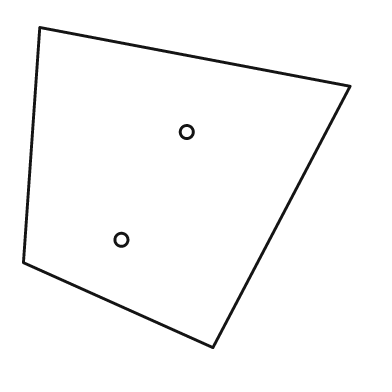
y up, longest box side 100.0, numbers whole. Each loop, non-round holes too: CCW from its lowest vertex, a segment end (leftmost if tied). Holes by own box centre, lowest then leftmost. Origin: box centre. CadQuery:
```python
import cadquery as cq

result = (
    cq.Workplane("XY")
    .moveTo(8.0, -49.0)
    .lineTo(50.0, 31.0)
    .lineTo(-45.0, 49.0)
    .lineTo(-50.0, -23.0)
    .close()
    .moveTo(-20.0, -16.0)
    .circle(2.0)
    .moveTo(0.0, 17.0)
    .circle(2.0)
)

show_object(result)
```